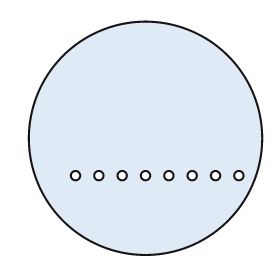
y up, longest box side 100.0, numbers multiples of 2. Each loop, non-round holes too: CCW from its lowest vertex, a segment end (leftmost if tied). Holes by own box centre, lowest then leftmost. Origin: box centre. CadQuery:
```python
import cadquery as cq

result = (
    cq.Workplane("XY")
    .moveTo(0.0, 0.0)
    .circle(50.0)
    .moveTo(-30.0, -16.0)
    .circle(2.0)
    .moveTo(-20.0, -16.0)
    .circle(2.0)
    .moveTo(-10.0, -16.0)
    .circle(2.0)
    .moveTo(0.0, -16.0)
    .circle(2.0)
    .moveTo(10.0, -16.0)
    .circle(2.0)
    .moveTo(20.0, -16.0)
    .circle(2.0)
    .moveTo(30.0, -16.0)
    .circle(2.0)
    .moveTo(40.0, -16.0)
    .circle(2.0)
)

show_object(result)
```